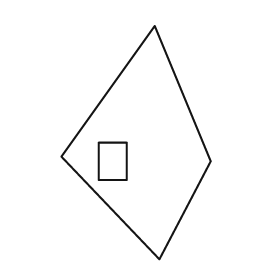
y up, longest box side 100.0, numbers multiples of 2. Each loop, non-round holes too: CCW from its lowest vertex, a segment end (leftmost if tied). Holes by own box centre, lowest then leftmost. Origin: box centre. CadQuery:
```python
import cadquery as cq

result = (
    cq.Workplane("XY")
    .moveTo(10.0, -50.0)
    .lineTo(32.0, -8.0)
    .lineTo(8.0, 50.0)
    .lineTo(-32.0, -6.0)
    .close()
    .moveTo(-16.0, -16.0)
    .lineTo(-4.0, -16.0)
    .lineTo(-4.0, 0.0)
    .lineTo(-16.0, 0.0)
    .close()
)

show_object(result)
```